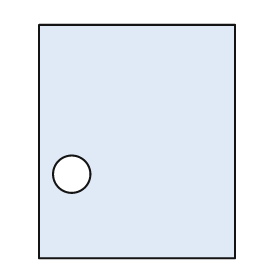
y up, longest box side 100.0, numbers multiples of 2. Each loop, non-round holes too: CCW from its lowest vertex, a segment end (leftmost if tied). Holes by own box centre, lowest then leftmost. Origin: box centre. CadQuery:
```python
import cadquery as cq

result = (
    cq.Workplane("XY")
    .moveTo(-42.0, -50.0)
    .lineTo(42.0, -50.0)
    .lineTo(42.0, 50.0)
    .lineTo(-42.0, 50.0)
    .close()
    .moveTo(-28.0, -14.0)
    .circle(8.0)
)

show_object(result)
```